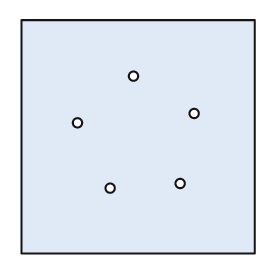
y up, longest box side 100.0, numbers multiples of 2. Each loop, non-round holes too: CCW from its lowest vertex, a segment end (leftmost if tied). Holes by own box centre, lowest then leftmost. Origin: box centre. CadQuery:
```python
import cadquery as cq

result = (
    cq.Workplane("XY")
    .moveTo(-50.0, -50.0)
    .lineTo(50.0, -50.0)
    .lineTo(50.0, 50.0)
    .lineTo(-50.0, 50.0)
    .close()
    .moveTo(-12.0, -22.0)
    .circle(2.0)
    .moveTo(18.0, -20.0)
    .circle(2.0)
    .moveTo(-26.0, 6.0)
    .circle(2.0)
    .moveTo(24.0, 10.0)
    .circle(2.0)
    .moveTo(-2.0, 26.0)
    .circle(2.0)
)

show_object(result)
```